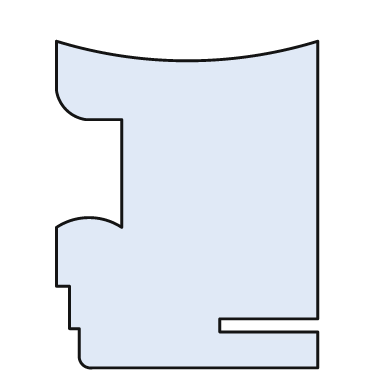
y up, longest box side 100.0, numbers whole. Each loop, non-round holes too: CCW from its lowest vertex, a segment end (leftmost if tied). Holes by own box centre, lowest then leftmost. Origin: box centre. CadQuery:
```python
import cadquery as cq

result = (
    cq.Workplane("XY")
    .moveTo(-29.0, -50.0)
    .lineTo(40.0, -50.0)
    .lineTo(40.0, -39.0)
    .lineTo(10.0, -39.0)
    .lineTo(10.0, -35.0)
    .lineTo(40.0, -35.0)
    .lineTo(40.0, 50.0)
    .threePointArc((0.0, 44.0), (-40.0, 50.0))
    .lineTo(-40.0, 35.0)
    .threePointArc((-37.0, 29.0), (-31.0, 26.0))
    .lineTo(-20.0, 26.0)
    .lineTo(-20.0, -7.0)
    .threePointArc((-30.0, -4.0), (-40.0, -7.0))
    .lineTo(-40.0, -25.0)
    .lineTo(-36.0, -25.0)
    .lineTo(-36.0, -38.0)
    .lineTo(-33.0, -38.0)
    .lineTo(-33.0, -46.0)
    .threePointArc((-32.0, -49.0), (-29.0, -50.0))
    .close()
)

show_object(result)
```